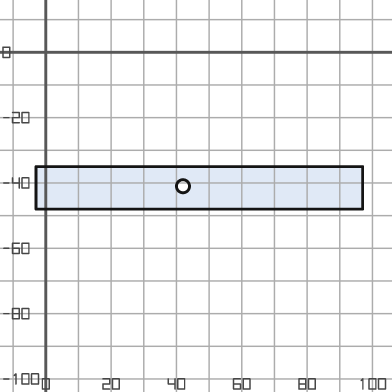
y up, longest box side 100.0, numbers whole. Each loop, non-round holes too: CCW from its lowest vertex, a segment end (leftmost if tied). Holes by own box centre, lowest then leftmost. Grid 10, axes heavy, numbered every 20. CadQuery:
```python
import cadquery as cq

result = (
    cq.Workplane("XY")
    .moveTo(-3.0, -48.0)
    .lineTo(97.0, -48.0)
    .lineTo(97.0, -35.0)
    .lineTo(-3.0, -35.0)
    .close()
    .moveTo(42.0, -41.0)
    .circle(2.0)
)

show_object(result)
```